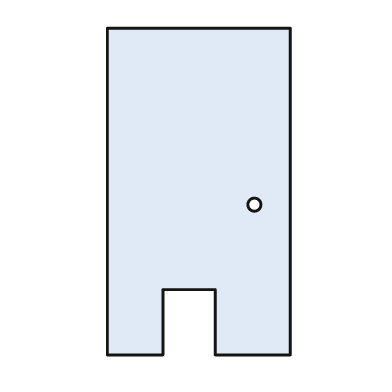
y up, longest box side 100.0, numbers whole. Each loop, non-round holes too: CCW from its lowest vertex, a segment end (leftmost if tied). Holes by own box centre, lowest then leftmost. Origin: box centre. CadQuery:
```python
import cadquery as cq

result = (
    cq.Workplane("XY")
    .moveTo(-28.0, -50.0)
    .lineTo(-11.0, -50.0)
    .lineTo(-11.0, -30.0)
    .lineTo(5.0, -30.0)
    .lineTo(5.0, -50.0)
    .lineTo(28.0, -50.0)
    .lineTo(28.0, 50.0)
    .lineTo(-28.0, 50.0)
    .close()
    .moveTo(17.0, -4.0)
    .circle(2.0)
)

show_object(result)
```